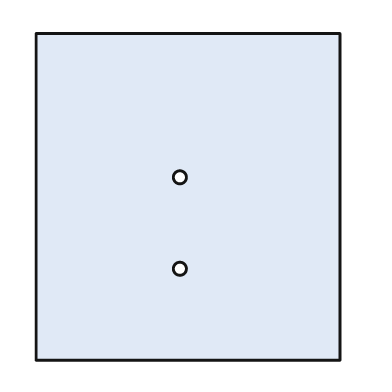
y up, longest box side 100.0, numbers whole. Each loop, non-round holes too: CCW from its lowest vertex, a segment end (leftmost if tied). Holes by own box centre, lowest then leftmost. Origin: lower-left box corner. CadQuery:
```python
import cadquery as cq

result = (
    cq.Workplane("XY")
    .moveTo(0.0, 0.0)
    .lineTo(93.0, 0.0)
    .lineTo(93.0, 100.0)
    .lineTo(0.0, 100.0)
    .close()
    .moveTo(44.0, 28.0)
    .circle(2.0)
    .moveTo(44.0, 56.0)
    .circle(2.0)
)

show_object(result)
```